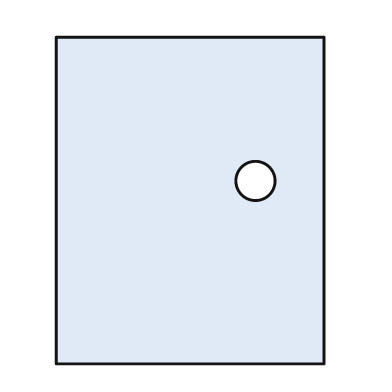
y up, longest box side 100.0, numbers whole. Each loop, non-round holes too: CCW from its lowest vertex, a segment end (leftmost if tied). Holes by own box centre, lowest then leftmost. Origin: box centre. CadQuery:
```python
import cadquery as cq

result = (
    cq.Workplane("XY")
    .moveTo(-41.0, -50.0)
    .lineTo(41.0, -50.0)
    .lineTo(41.0, 50.0)
    .lineTo(-41.0, 50.0)
    .close()
    .moveTo(20.0, 6.0)
    .circle(6.0)
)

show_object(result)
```